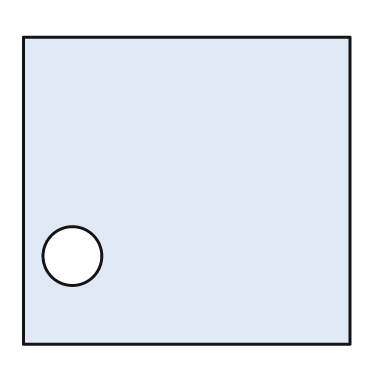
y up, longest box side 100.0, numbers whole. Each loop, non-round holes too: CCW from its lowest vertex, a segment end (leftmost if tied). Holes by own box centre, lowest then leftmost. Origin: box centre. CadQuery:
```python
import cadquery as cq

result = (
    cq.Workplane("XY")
    .moveTo(-50.0, -47.0)
    .lineTo(50.0, -47.0)
    .lineTo(50.0, 47.0)
    .lineTo(-50.0, 47.0)
    .close()
    .moveTo(-35.0, -20.0)
    .circle(9.0)
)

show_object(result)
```